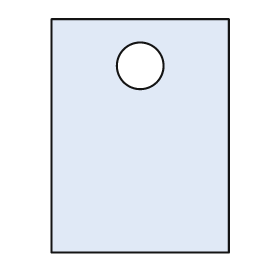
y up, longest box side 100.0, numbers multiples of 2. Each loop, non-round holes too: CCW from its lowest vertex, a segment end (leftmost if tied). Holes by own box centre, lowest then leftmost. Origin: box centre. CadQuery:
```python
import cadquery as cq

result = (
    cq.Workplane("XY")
    .moveTo(-38.0, -50.0)
    .lineTo(38.0, -50.0)
    .lineTo(38.0, 50.0)
    .lineTo(-38.0, 50.0)
    .close()
    .moveTo(0.0, 30.0)
    .circle(10.0)
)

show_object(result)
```